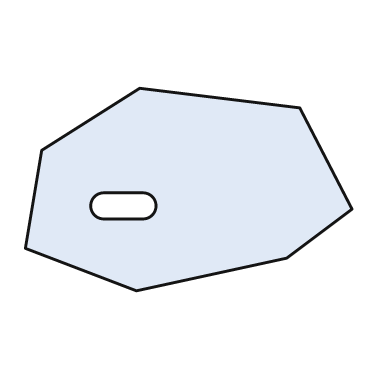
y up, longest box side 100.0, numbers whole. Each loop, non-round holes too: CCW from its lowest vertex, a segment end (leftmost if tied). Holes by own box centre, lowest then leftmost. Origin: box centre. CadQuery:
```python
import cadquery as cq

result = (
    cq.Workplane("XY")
    .moveTo(-16.0, -31.0)
    .lineTo(30.0, -21.0)
    .lineTo(50.0, -6.0)
    .lineTo(34.0, 25.0)
    .lineTo(-15.0, 31.0)
    .lineTo(-45.0, 12.0)
    .lineTo(-50.0, -18.0)
    .close()
    .moveTo(-26.0, -9.0)
    .lineTo(-14.0, -9.0)
    .threePointArc((-10.0, -5.0), (-14.0, -1.0))
    .lineTo(-26.0, -1.0)
    .threePointArc((-30.0, -5.0), (-26.0, -9.0))
    .close()
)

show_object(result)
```